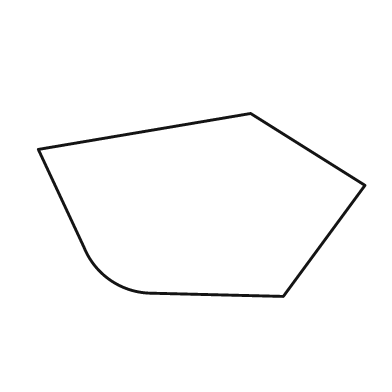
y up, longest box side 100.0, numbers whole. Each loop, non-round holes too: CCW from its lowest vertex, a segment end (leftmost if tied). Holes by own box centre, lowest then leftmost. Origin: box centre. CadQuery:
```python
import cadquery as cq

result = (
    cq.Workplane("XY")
    .moveTo(25.0, -28.0)
    .lineTo(50.0, 6.0)
    .lineTo(15.0, 28.0)
    .lineTo(-50.0, 17.0)
    .lineTo(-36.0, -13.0)
    .threePointArc((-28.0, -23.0), (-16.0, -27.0))
    .close()
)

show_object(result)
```